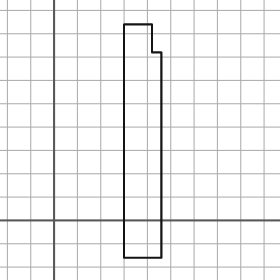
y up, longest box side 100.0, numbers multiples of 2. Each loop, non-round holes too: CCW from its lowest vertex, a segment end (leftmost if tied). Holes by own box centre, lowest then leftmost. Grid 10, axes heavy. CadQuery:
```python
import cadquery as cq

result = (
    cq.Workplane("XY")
    .moveTo(30.0, -16.0)
    .lineTo(46.0, -16.0)
    .lineTo(46.0, 72.0)
    .lineTo(42.0, 72.0)
    .lineTo(42.0, 84.0)
    .lineTo(30.0, 84.0)
    .close()
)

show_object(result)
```